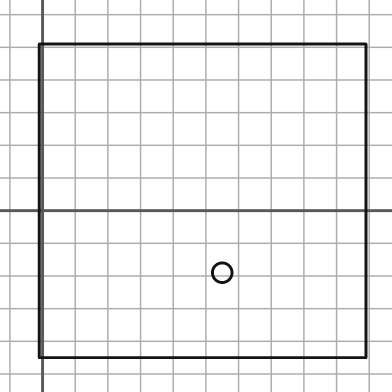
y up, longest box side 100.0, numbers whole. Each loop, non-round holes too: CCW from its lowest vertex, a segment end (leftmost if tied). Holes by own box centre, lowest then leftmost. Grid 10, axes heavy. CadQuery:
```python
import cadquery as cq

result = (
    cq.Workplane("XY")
    .moveTo(-1.0, -45.0)
    .lineTo(99.0, -45.0)
    .lineTo(99.0, 51.0)
    .lineTo(-1.0, 51.0)
    .close()
    .moveTo(55.0, -19.0)
    .circle(3.0)
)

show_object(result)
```